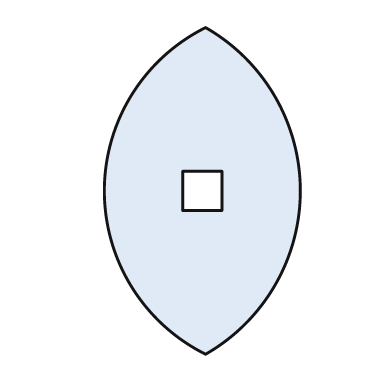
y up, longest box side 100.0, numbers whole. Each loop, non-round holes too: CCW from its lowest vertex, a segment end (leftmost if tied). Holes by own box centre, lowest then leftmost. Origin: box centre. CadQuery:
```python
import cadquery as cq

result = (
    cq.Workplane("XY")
    .moveTo(1.0, -50.0)
    .threePointArc((30.0, 0.0), (1.0, 50.0))
    .threePointArc((-30.0, 0.0), (1.0, -50.0))
    .close()
    .moveTo(-6.0, -6.0)
    .lineTo(6.0, -6.0)
    .lineTo(6.0, 6.0)
    .lineTo(-6.0, 6.0)
    .close()
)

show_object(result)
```